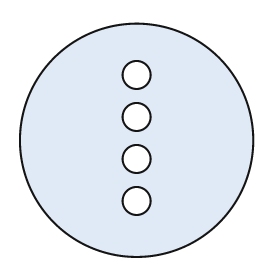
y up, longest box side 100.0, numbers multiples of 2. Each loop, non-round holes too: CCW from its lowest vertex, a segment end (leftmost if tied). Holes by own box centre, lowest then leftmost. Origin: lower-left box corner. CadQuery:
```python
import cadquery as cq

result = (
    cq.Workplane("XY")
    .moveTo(50.0, 50.0)
    .circle(50.0)
    .moveTo(50.0, 24.0)
    .circle(6.0)
    .moveTo(50.0, 42.0)
    .circle(6.0)
    .moveTo(50.0, 60.0)
    .circle(6.0)
    .moveTo(50.0, 78.0)
    .circle(6.0)
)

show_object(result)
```